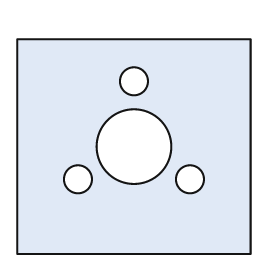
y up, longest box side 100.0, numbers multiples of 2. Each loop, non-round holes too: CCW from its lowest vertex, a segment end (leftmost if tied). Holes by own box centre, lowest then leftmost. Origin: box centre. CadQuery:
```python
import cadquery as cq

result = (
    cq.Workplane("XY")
    .moveTo(-50.0, -46.0)
    .lineTo(50.0, -46.0)
    .lineTo(50.0, 46.0)
    .lineTo(-50.0, 46.0)
    .close()
    .moveTo(-24.0, -14.0)
    .circle(6.0)
    .moveTo(24.0, -14.0)
    .circle(6.0)
    .moveTo(0.0, 0.0)
    .circle(16.0)
    .moveTo(0.0, 28.0)
    .circle(6.0)
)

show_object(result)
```